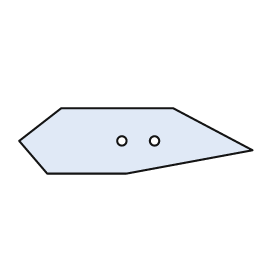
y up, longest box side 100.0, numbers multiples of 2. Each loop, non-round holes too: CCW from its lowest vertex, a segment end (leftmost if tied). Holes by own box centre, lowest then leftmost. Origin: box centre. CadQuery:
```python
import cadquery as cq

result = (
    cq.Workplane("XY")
    .moveTo(-38.0, -14.0)
    .lineTo(-4.0, -14.0)
    .lineTo(50.0, -4.0)
    .lineTo(16.0, 14.0)
    .lineTo(-32.0, 14.0)
    .lineTo(-50.0, 0.0)
    .close()
    .moveTo(-6.0, 0.0)
    .circle(2.0)
    .moveTo(8.0, 0.0)
    .circle(2.0)
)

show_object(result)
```